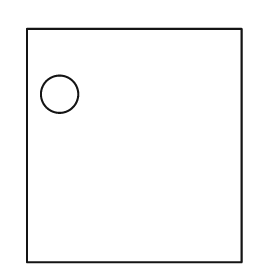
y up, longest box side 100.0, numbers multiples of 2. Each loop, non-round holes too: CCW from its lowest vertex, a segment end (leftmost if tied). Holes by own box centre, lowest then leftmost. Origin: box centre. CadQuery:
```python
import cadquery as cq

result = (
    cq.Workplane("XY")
    .moveTo(-46.0, -50.0)
    .lineTo(46.0, -50.0)
    .lineTo(46.0, 50.0)
    .lineTo(-46.0, 50.0)
    .close()
    .moveTo(-32.0, 22.0)
    .circle(8.0)
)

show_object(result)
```